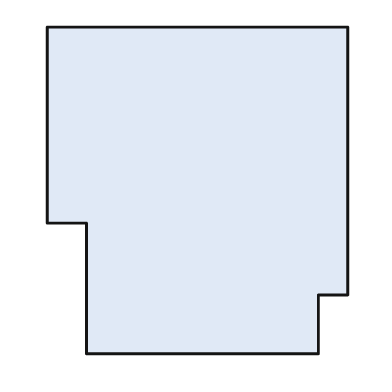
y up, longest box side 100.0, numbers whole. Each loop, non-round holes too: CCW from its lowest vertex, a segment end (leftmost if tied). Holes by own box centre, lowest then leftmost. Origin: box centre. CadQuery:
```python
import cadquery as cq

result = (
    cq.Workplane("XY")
    .moveTo(-34.0, -50.0)
    .lineTo(37.0, -50.0)
    .lineTo(37.0, -32.0)
    .lineTo(46.0, -32.0)
    .lineTo(46.0, 50.0)
    .lineTo(-46.0, 50.0)
    .lineTo(-46.0, -10.0)
    .lineTo(-34.0, -10.0)
    .close()
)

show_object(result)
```